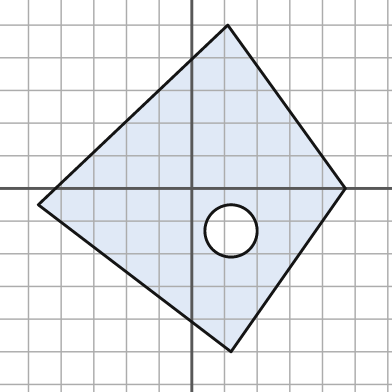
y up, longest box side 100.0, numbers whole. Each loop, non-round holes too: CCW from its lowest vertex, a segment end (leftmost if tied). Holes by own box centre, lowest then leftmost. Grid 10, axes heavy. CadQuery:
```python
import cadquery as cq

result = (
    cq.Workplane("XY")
    .moveTo(12.0, -50.0)
    .lineTo(47.0, 0.0)
    .lineTo(11.0, 50.0)
    .lineTo(-47.0, -5.0)
    .close()
    .moveTo(12.0, -13.0)
    .circle(8.0)
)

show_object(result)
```